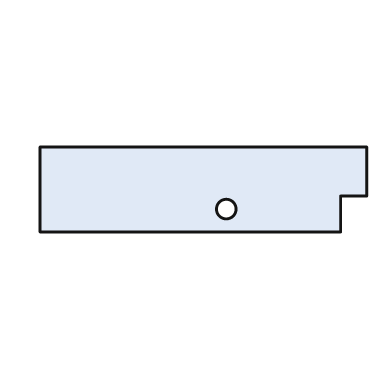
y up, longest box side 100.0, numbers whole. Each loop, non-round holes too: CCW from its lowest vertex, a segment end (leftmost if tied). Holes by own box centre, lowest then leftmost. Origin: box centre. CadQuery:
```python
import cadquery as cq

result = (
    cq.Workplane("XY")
    .moveTo(-50.0, -13.0)
    .lineTo(42.0, -13.0)
    .lineTo(42.0, -2.0)
    .lineTo(50.0, -2.0)
    .lineTo(50.0, 13.0)
    .lineTo(-50.0, 13.0)
    .close()
    .moveTo(7.0, -6.0)
    .circle(3.0)
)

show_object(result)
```